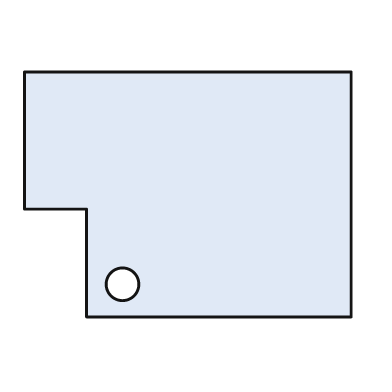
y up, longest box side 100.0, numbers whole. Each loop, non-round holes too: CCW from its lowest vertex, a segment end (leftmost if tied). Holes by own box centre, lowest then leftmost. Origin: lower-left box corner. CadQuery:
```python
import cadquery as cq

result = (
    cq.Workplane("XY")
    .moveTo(19.0, 0.0)
    .lineTo(100.0, 0.0)
    .lineTo(100.0, 75.0)
    .lineTo(0.0, 75.0)
    .lineTo(0.0, 33.0)
    .lineTo(19.0, 33.0)
    .close()
    .moveTo(30.0, 10.0)
    .circle(5.0)
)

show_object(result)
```